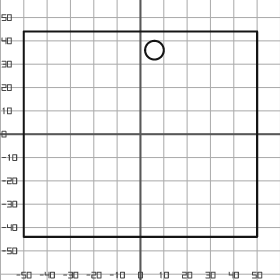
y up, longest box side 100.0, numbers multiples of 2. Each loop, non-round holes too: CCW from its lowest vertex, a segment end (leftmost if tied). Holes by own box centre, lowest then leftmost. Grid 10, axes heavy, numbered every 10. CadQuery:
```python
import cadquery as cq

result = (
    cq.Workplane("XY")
    .moveTo(-50.0, -44.0)
    .lineTo(50.0, -44.0)
    .lineTo(50.0, 44.0)
    .lineTo(-50.0, 44.0)
    .close()
    .moveTo(6.0, 36.0)
    .circle(4.0)
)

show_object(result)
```